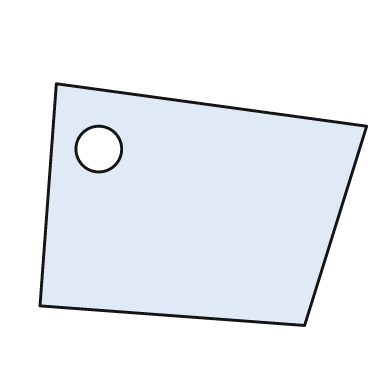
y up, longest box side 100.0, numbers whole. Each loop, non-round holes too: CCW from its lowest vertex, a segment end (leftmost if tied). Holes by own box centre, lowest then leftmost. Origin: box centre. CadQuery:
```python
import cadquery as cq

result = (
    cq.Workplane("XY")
    .moveTo(31.0, -37.0)
    .lineTo(50.0, 24.0)
    .lineTo(-45.0, 37.0)
    .lineTo(-50.0, -31.0)
    .close()
    .moveTo(-32.0, 17.0)
    .circle(7.0)
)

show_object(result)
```